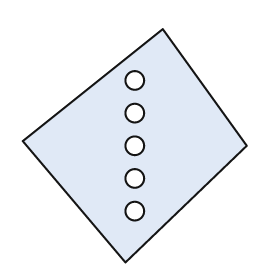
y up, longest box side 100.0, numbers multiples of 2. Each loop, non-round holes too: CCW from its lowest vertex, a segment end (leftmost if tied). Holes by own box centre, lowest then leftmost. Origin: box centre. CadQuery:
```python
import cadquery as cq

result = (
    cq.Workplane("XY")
    .moveTo(-4.0, -50.0)
    .lineTo(48.0, 0.0)
    .lineTo(12.0, 50.0)
    .lineTo(-48.0, 2.0)
    .close()
    .moveTo(0.0, -28.0)
    .circle(4.0)
    .moveTo(0.0, -14.0)
    .circle(4.0)
    .moveTo(0.0, 0.0)
    .circle(4.0)
    .moveTo(0.0, 14.0)
    .circle(4.0)
    .moveTo(0.0, 28.0)
    .circle(4.0)
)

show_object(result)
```